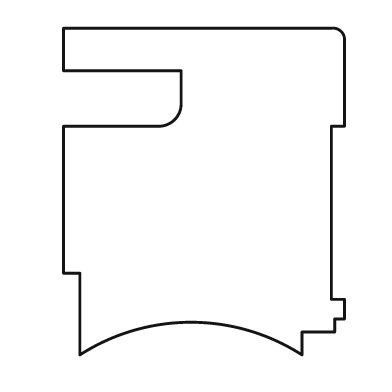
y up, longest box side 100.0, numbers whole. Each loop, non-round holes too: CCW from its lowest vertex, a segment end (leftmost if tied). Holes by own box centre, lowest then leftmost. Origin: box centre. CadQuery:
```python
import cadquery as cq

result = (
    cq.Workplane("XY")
    .moveTo(-38.0, -50.0)
    .threePointArc((-4.0, -40.0), (30.0, -50.0))
    .lineTo(30.0, -43.0)
    .lineTo(40.0, -43.0)
    .lineTo(40.0, -39.0)
    .lineTo(43.0, -39.0)
    .lineTo(43.0, -33.0)
    .lineTo(39.0, -33.0)
    .lineTo(39.0, 20.0)
    .lineTo(43.0, 20.0)
    .lineTo(43.0, 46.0)
    .threePointArc((42.0, 49.0), (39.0, 50.0))
    .lineTo(-43.0, 50.0)
    .lineTo(-43.0, 37.0)
    .lineTo(-7.0, 37.0)
    .lineTo(-7.0, 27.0)
    .threePointArc((-9.0, 22.0), (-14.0, 20.0))
    .lineTo(-43.0, 20.0)
    .lineTo(-43.0, -25.0)
    .lineTo(-38.0, -25.0)
    .close()
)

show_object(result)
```